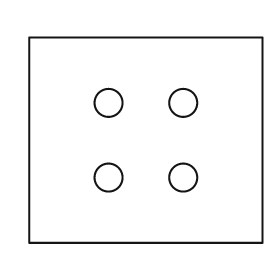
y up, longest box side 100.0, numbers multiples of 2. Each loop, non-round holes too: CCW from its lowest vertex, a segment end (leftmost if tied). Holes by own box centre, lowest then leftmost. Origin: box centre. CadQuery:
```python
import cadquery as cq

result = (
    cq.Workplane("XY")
    .moveTo(-50.0, -44.0)
    .lineTo(50.0, -44.0)
    .lineTo(50.0, 44.0)
    .lineTo(-50.0, 44.0)
    .close()
    .moveTo(-16.0, -16.0)
    .circle(6.0)
    .moveTo(16.0, -16.0)
    .circle(6.0)
    .moveTo(-16.0, 16.0)
    .circle(6.0)
    .moveTo(16.0, 16.0)
    .circle(6.0)
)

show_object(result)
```